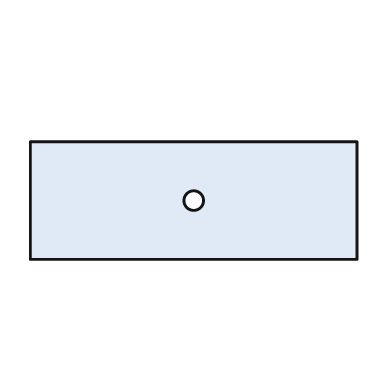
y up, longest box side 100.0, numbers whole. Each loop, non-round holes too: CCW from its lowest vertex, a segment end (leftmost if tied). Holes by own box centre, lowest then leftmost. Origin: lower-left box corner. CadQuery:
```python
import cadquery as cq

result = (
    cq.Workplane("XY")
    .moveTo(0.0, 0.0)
    .lineTo(100.0, 0.0)
    .lineTo(100.0, 36.0)
    .lineTo(0.0, 36.0)
    .close()
    .moveTo(50.0, 18.0)
    .circle(3.0)
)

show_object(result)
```